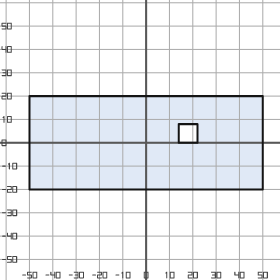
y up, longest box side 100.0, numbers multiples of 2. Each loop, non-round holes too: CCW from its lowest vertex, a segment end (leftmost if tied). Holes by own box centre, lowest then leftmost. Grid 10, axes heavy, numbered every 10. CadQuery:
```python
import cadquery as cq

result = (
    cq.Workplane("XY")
    .moveTo(-50.0, -20.0)
    .lineTo(50.0, -20.0)
    .lineTo(50.0, 20.0)
    .lineTo(-50.0, 20.0)
    .close()
    .moveTo(14.0, 0.0)
    .lineTo(22.0, 0.0)
    .lineTo(22.0, 8.0)
    .lineTo(14.0, 8.0)
    .close()
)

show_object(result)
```